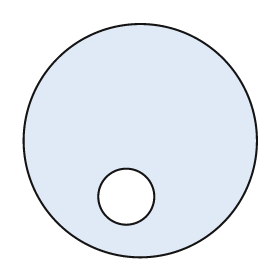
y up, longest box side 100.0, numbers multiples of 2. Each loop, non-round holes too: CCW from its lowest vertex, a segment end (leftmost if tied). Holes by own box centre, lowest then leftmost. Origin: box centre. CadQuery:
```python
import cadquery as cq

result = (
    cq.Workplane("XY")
    .moveTo(0.0, 0.0)
    .circle(50.0)
    .moveTo(-6.0, -24.0)
    .circle(12.0)
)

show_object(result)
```